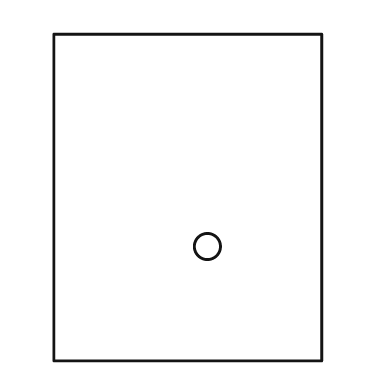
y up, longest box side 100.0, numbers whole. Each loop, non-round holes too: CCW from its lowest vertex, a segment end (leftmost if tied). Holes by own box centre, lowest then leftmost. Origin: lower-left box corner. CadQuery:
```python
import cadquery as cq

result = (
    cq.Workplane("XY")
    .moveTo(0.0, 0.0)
    .lineTo(82.0, 0.0)
    .lineTo(82.0, 100.0)
    .lineTo(0.0, 100.0)
    .close()
    .moveTo(47.0, 35.0)
    .circle(4.0)
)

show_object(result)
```